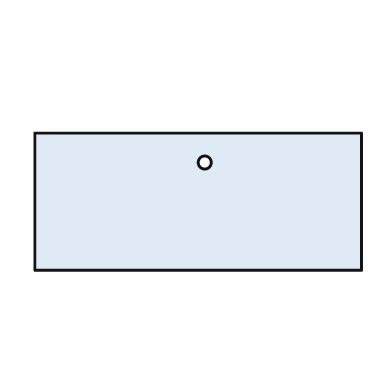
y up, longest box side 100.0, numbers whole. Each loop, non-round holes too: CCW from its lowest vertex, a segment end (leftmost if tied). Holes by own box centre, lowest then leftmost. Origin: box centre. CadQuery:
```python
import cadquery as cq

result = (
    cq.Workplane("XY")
    .moveTo(-50.0, -21.0)
    .lineTo(50.0, -21.0)
    .lineTo(50.0, 21.0)
    .lineTo(-50.0, 21.0)
    .close()
    .moveTo(2.0, 12.0)
    .circle(2.0)
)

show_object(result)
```